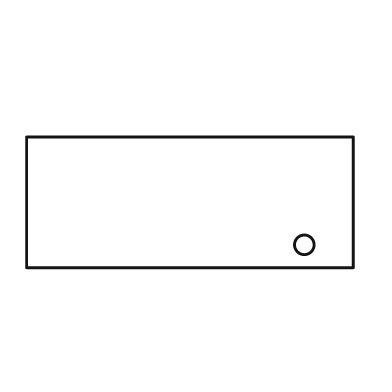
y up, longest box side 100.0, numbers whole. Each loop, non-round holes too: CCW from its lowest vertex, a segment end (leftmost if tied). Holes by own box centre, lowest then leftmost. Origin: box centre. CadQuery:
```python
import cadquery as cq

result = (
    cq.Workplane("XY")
    .moveTo(-50.0, -20.0)
    .lineTo(50.0, -20.0)
    .lineTo(50.0, 20.0)
    .lineTo(-50.0, 20.0)
    .close()
    .moveTo(35.0, -13.0)
    .circle(3.0)
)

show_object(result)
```